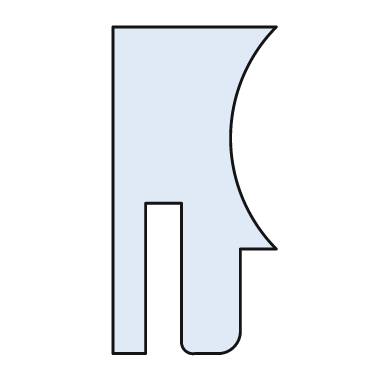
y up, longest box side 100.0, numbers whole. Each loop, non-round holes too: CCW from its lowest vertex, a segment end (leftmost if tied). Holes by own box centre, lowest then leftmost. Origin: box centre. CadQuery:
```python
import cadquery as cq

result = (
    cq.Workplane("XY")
    .moveTo(-25.0, -50.0)
    .lineTo(-15.0, -50.0)
    .lineTo(-15.0, -4.0)
    .lineTo(-4.0, -4.0)
    .lineTo(-4.0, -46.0)
    .threePointArc((-3.0, -49.0), (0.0, -50.0))
    .lineTo(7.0, -50.0)
    .threePointArc((12.0, -48.0), (14.0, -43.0))
    .lineTo(14.0, -18.0)
    .lineTo(25.0, -18.0)
    .threePointArc((11.0, 16.0), (25.0, 50.0))
    .lineTo(-25.0, 50.0)
    .close()
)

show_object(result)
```